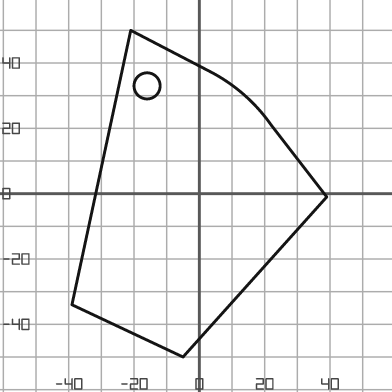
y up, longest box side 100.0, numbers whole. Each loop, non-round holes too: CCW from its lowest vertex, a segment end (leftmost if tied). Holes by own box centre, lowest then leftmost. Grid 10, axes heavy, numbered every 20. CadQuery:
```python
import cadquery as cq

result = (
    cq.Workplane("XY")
    .moveTo(-5.0, -50.0)
    .lineTo(39.0, -1.0)
    .lineTo(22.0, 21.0)
    .threePointArc((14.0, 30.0), (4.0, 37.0))
    .lineTo(-21.0, 50.0)
    .lineTo(-39.0, -34.0)
    .close()
    .moveTo(-16.0, 33.0)
    .circle(4.0)
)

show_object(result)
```